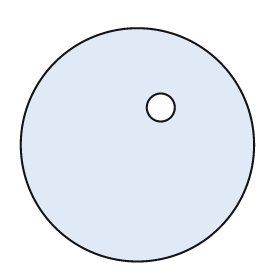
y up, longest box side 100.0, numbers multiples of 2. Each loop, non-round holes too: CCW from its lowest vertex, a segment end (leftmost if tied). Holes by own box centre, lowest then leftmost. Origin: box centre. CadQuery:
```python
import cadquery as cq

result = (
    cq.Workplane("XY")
    .moveTo(0.0, 0.0)
    .circle(50.0)
    .moveTo(10.0, 16.0)
    .circle(6.0)
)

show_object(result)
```